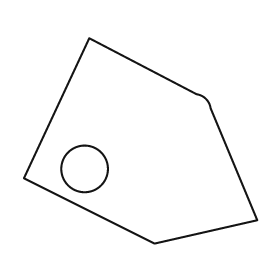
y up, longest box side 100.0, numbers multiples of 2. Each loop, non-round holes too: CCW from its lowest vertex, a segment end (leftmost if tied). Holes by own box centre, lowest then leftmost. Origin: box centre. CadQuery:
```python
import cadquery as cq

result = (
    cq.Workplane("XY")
    .moveTo(6.0, -44.0)
    .lineTo(50.0, -34.0)
    .lineTo(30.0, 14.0)
    .threePointArc((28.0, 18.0), (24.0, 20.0))
    .lineTo(-22.0, 44.0)
    .lineTo(-50.0, -16.0)
    .close()
    .moveTo(-24.0, -12.0)
    .circle(10.0)
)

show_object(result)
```